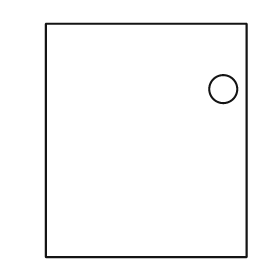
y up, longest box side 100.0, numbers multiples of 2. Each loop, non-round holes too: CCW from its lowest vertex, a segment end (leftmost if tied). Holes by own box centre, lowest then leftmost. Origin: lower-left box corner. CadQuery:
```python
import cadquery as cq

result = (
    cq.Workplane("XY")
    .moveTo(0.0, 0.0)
    .lineTo(86.0, 0.0)
    .lineTo(86.0, 100.0)
    .lineTo(0.0, 100.0)
    .close()
    .moveTo(76.0, 72.0)
    .circle(6.0)
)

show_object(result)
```